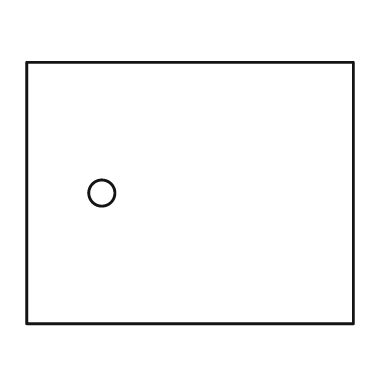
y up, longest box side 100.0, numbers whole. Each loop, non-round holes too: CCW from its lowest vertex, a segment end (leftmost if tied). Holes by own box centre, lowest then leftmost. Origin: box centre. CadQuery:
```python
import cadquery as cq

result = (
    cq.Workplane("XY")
    .moveTo(-50.0, -40.0)
    .lineTo(50.0, -40.0)
    .lineTo(50.0, 40.0)
    .lineTo(-50.0, 40.0)
    .close()
    .moveTo(-27.0, 0.0)
    .circle(4.0)
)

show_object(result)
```